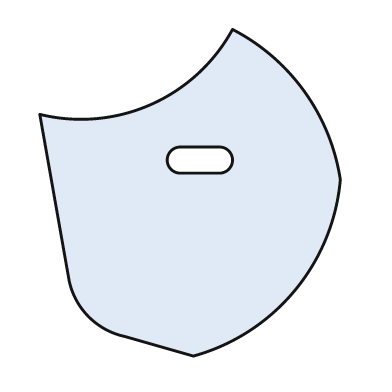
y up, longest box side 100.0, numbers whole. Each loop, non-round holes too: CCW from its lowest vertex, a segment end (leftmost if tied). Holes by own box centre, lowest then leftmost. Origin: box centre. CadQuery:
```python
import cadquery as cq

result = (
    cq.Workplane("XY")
    .moveTo(1.0, -50.0)
    .threePointArc((32.0, -30.0), (46.0, 4.0))
    .threePointArc((35.0, 31.0), (13.0, 50.0))
    .threePointArc((-12.0, 27.0), (-46.0, 24.0))
    .lineTo(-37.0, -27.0)
    .threePointArc((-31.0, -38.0), (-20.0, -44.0))
    .close()
    .moveTo(-3.0, 6.0)
    .lineTo(9.0, 6.0)
    .threePointArc((13.0, 10.0), (9.0, 14.0))
    .lineTo(-3.0, 14.0)
    .threePointArc((-7.0, 10.0), (-3.0, 6.0))
    .close()
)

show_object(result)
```